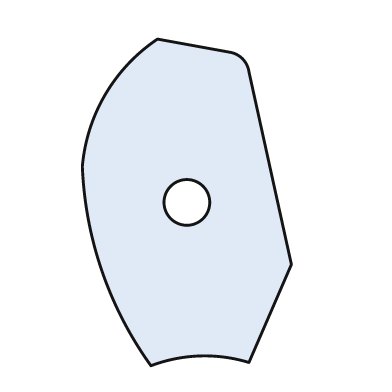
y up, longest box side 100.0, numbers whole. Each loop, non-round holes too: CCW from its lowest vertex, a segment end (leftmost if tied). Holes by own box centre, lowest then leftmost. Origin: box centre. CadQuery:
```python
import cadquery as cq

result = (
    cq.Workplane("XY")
    .moveTo(-11.0, -50.0)
    .threePointArc((4.0, -47.0), (19.0, -49.0))
    .lineTo(32.0, -19.0)
    .lineTo(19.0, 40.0)
    .threePointArc((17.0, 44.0), (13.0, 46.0))
    .lineTo(-9.0, 50.0)
    .threePointArc((-25.0, 33.0), (-32.0, 11.0))
    .threePointArc((-26.0, -21.0), (-11.0, -50.0))
    .close()
    .moveTo(0.0, 0.0)
    .circle(7.0)
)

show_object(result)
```